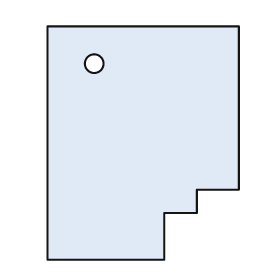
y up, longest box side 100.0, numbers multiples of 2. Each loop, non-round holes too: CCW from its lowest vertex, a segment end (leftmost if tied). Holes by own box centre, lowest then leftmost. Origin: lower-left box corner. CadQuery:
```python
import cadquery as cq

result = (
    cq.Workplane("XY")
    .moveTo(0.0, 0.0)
    .lineTo(50.0, 0.0)
    .lineTo(50.0, 20.0)
    .lineTo(64.0, 20.0)
    .lineTo(64.0, 30.0)
    .lineTo(82.0, 30.0)
    .lineTo(82.0, 100.0)
    .lineTo(0.0, 100.0)
    .close()
    .moveTo(20.0, 84.0)
    .circle(4.0)
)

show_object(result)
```